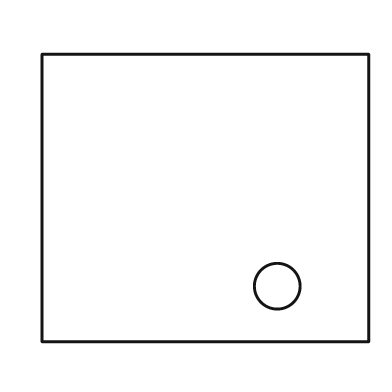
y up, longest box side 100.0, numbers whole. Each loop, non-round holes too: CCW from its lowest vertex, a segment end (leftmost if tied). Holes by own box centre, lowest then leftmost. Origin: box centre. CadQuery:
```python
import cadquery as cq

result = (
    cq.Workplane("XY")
    .moveTo(-50.0, -44.0)
    .lineTo(50.0, -44.0)
    .lineTo(50.0, 44.0)
    .lineTo(-50.0, 44.0)
    .close()
    .moveTo(22.0, -27.0)
    .circle(7.0)
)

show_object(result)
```